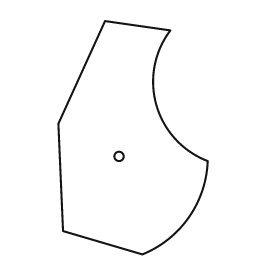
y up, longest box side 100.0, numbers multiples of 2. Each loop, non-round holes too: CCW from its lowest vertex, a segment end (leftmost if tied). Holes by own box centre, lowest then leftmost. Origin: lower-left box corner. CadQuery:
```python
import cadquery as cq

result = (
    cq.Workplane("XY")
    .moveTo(36.0, 0.0)
    .threePointArc((56.0, 16.0), (64.0, 40.0))
    .threePointArc((42.0, 64.0), (48.0, 96.0))
    .lineTo(20.0, 100.0)
    .lineTo(0.0, 56.0)
    .lineTo(2.0, 10.0)
    .close()
    .moveTo(26.0, 42.0)
    .circle(2.0)
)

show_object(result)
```